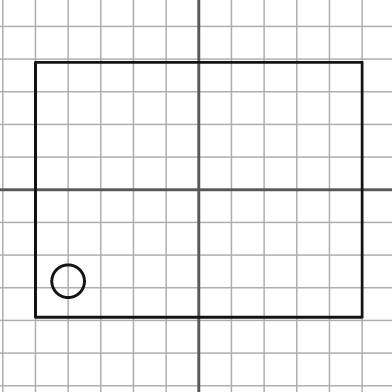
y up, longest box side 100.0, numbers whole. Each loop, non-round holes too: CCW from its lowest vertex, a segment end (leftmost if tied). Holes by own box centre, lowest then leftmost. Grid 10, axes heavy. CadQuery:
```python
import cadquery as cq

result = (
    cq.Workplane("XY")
    .moveTo(-50.0, -39.0)
    .lineTo(50.0, -39.0)
    .lineTo(50.0, 39.0)
    .lineTo(-50.0, 39.0)
    .close()
    .moveTo(-40.0, -28.0)
    .circle(5.0)
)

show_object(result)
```